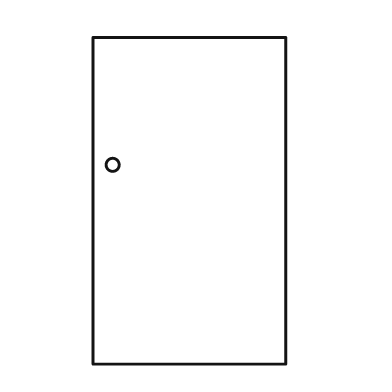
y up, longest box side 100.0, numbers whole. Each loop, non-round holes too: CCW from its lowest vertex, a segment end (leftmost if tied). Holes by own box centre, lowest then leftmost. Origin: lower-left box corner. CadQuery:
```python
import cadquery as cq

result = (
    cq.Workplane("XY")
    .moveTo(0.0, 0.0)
    .lineTo(59.0, 0.0)
    .lineTo(59.0, 100.0)
    .lineTo(0.0, 100.0)
    .close()
    .moveTo(6.0, 61.0)
    .circle(2.0)
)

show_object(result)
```